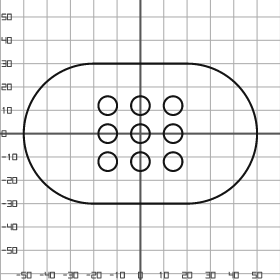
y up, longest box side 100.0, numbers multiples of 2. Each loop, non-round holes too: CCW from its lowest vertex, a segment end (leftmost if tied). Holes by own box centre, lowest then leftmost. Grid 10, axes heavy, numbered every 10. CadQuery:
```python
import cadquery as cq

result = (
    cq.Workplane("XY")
    .moveTo(-20.0, -30.0)
    .lineTo(20.0, -30.0)
    .threePointArc((50.0, 0.0), (20.0, 30.0))
    .lineTo(-20.0, 30.0)
    .threePointArc((-50.0, 0.0), (-20.0, -30.0))
    .close()
    .moveTo(-14.0, -12.0)
    .circle(4.0)
    .moveTo(0.0, -12.0)
    .circle(4.0)
    .moveTo(14.0, -12.0)
    .circle(4.0)
    .moveTo(-14.0, 0.0)
    .circle(4.0)
    .moveTo(0.0, 0.0)
    .circle(4.0)
    .moveTo(14.0, 0.0)
    .circle(4.0)
    .moveTo(-14.0, 12.0)
    .circle(4.0)
    .moveTo(0.0, 12.0)
    .circle(4.0)
    .moveTo(14.0, 12.0)
    .circle(4.0)
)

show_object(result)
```